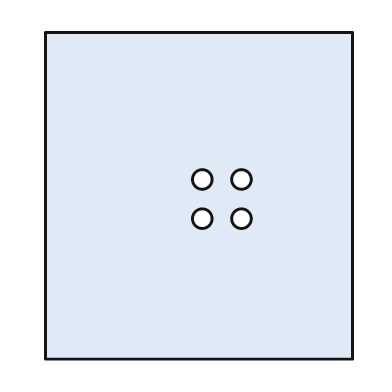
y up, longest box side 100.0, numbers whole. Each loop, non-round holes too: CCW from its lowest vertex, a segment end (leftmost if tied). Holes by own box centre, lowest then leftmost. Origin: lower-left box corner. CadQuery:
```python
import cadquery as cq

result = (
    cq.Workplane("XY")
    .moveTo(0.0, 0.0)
    .lineTo(94.0, 0.0)
    .lineTo(94.0, 100.0)
    .lineTo(0.0, 100.0)
    .close()
    .moveTo(48.0, 43.0)
    .circle(3.0)
    .moveTo(60.0, 43.0)
    .circle(3.0)
    .moveTo(48.0, 55.0)
    .circle(3.0)
    .moveTo(60.0, 55.0)
    .circle(3.0)
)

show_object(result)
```